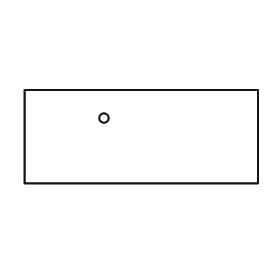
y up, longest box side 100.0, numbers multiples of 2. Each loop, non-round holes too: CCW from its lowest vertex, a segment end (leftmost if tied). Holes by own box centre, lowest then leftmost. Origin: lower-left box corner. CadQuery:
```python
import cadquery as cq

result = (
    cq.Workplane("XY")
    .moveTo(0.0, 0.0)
    .lineTo(100.0, 0.0)
    .lineTo(100.0, 40.0)
    .lineTo(0.0, 40.0)
    .close()
    .moveTo(34.0, 28.0)
    .circle(2.0)
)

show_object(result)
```